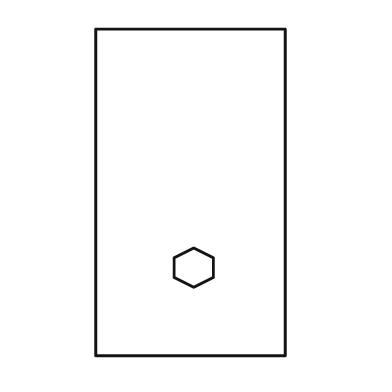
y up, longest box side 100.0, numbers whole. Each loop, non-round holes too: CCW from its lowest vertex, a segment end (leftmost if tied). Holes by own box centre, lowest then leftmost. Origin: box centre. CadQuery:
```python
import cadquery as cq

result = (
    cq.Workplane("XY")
    .moveTo(-29.0, -50.0)
    .lineTo(29.0, -50.0)
    .lineTo(29.0, 50.0)
    .lineTo(-29.0, 50.0)
    .close()
    .moveTo(1.0, -29.0)
    .lineTo(7.0, -26.0)
    .lineTo(7.0, -20.0)
    .lineTo(1.0, -17.0)
    .lineTo(-5.0, -20.0)
    .lineTo(-5.0, -26.0)
    .close()
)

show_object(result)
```